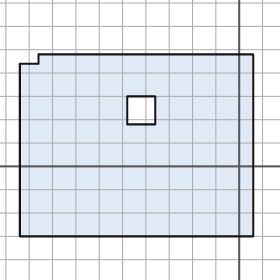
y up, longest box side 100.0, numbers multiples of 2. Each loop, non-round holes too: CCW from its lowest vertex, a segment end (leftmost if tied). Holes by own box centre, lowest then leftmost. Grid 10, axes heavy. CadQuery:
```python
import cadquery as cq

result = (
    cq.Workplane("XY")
    .moveTo(-94.0, -30.0)
    .lineTo(6.0, -30.0)
    .lineTo(6.0, 48.0)
    .lineTo(-86.0, 48.0)
    .lineTo(-86.0, 44.0)
    .lineTo(-94.0, 44.0)
    .close()
    .moveTo(-48.0, 18.0)
    .lineTo(-36.0, 18.0)
    .lineTo(-36.0, 30.0)
    .lineTo(-48.0, 30.0)
    .close()
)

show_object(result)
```